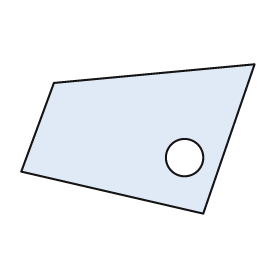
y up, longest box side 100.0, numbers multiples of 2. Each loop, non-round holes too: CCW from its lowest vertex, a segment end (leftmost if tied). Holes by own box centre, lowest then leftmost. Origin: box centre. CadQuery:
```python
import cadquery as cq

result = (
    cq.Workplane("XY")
    .moveTo(28.0, -32.0)
    .lineTo(50.0, 32.0)
    .lineTo(-36.0, 24.0)
    .lineTo(-50.0, -14.0)
    .close()
    .moveTo(20.0, -8.0)
    .circle(8.0)
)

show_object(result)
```